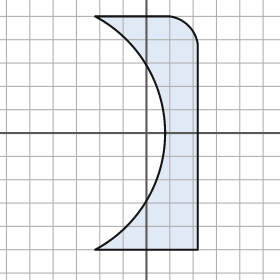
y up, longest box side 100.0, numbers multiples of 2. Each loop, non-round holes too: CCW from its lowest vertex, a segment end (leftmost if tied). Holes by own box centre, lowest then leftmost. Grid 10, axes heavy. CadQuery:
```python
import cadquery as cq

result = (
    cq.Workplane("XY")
    .moveTo(-22.0, -50.0)
    .lineTo(22.0, -50.0)
    .lineTo(22.0, 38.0)
    .threePointArc((18.0, 46.0), (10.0, 50.0))
    .lineTo(-22.0, 50.0)
    .threePointArc((8.0, 0.0), (-22.0, -50.0))
    .close()
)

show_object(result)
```